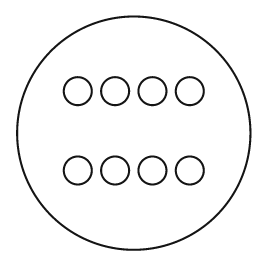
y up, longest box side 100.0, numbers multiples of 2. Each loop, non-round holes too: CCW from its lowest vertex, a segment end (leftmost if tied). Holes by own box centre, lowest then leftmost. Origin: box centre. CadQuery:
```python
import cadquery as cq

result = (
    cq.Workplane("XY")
    .moveTo(0.0, 0.0)
    .circle(50.0)
    .moveTo(-24.0, -16.0)
    .circle(6.0)
    .moveTo(-8.0, -16.0)
    .circle(6.0)
    .moveTo(8.0, -16.0)
    .circle(6.0)
    .moveTo(24.0, -16.0)
    .circle(6.0)
    .moveTo(-24.0, 18.0)
    .circle(6.0)
    .moveTo(-8.0, 18.0)
    .circle(6.0)
    .moveTo(8.0, 18.0)
    .circle(6.0)
    .moveTo(24.0, 18.0)
    .circle(6.0)
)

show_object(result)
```